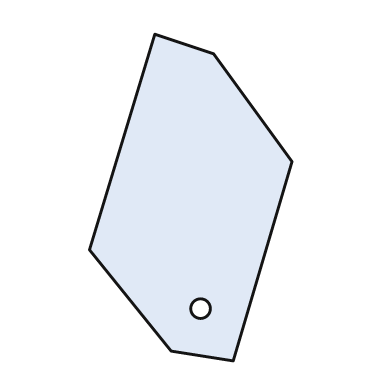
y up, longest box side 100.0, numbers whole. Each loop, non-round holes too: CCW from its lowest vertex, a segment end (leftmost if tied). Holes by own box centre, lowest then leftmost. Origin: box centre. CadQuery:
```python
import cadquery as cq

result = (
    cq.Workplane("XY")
    .moveTo(13.0, -50.0)
    .lineTo(31.0, 11.0)
    .lineTo(7.0, 44.0)
    .lineTo(-11.0, 50.0)
    .lineTo(-31.0, -16.0)
    .lineTo(-6.0, -47.0)
    .close()
    .moveTo(3.0, -34.0)
    .circle(3.0)
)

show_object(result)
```